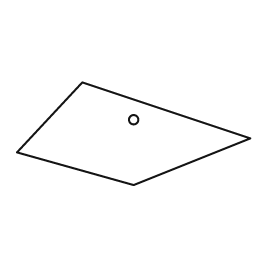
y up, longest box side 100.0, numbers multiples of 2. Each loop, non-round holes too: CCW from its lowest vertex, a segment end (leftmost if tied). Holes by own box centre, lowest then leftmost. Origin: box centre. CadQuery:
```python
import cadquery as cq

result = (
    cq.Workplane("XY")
    .moveTo(0.0, -22.0)
    .lineTo(50.0, -2.0)
    .lineTo(-22.0, 22.0)
    .lineTo(-50.0, -8.0)
    .close()
    .moveTo(0.0, 6.0)
    .circle(2.0)
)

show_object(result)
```